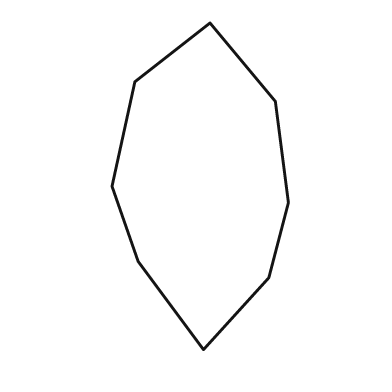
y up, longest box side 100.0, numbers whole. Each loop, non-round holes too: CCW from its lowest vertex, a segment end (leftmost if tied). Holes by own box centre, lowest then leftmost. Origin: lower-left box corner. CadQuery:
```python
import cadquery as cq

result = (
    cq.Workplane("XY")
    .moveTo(28.0, 0.0)
    .lineTo(48.0, 22.0)
    .lineTo(54.0, 45.0)
    .lineTo(50.0, 76.0)
    .lineTo(30.0, 100.0)
    .lineTo(7.0, 82.0)
    .lineTo(0.0, 50.0)
    .lineTo(8.0, 27.0)
    .close()
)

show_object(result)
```